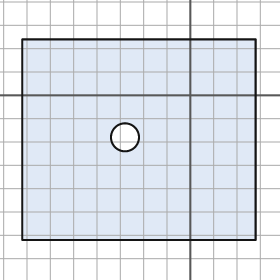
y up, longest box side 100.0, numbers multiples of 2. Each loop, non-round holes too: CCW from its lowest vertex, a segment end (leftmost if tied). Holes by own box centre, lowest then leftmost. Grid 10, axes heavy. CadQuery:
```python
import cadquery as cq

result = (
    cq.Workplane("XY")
    .moveTo(-72.0, -62.0)
    .lineTo(28.0, -62.0)
    .lineTo(28.0, 24.0)
    .lineTo(-72.0, 24.0)
    .close()
    .moveTo(-28.0, -18.0)
    .circle(6.0)
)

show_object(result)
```